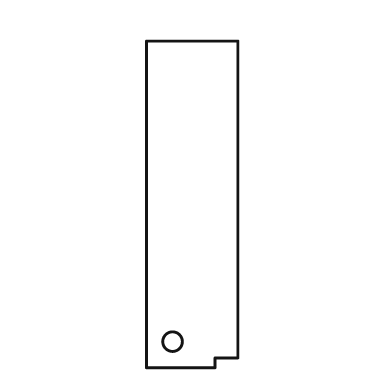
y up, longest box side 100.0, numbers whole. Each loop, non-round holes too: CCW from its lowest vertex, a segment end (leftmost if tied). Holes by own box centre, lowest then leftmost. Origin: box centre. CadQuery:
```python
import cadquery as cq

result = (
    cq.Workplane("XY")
    .moveTo(-14.0, -50.0)
    .lineTo(7.0, -50.0)
    .lineTo(7.0, -47.0)
    .lineTo(14.0, -47.0)
    .lineTo(14.0, 50.0)
    .lineTo(-14.0, 50.0)
    .close()
    .moveTo(-6.0, -42.0)
    .circle(3.0)
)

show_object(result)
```